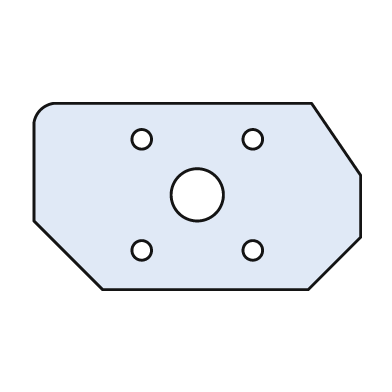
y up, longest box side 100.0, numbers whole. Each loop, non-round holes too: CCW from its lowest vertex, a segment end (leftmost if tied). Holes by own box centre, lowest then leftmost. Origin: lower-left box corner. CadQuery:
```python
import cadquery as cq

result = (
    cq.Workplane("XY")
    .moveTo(21.0, 0.0)
    .lineTo(84.0, 0.0)
    .lineTo(100.0, 16.0)
    .lineTo(100.0, 35.0)
    .lineTo(85.0, 57.0)
    .lineTo(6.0, 57.0)
    .threePointArc((2.0, 55.0), (0.0, 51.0))
    .lineTo(0.0, 21.0)
    .close()
    .moveTo(33.0, 12.0)
    .circle(3.0)
    .moveTo(67.0, 12.0)
    .circle(3.0)
    .moveTo(50.0, 29.0)
    .circle(8.0)
    .moveTo(33.0, 46.0)
    .circle(3.0)
    .moveTo(67.0, 46.0)
    .circle(3.0)
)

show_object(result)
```